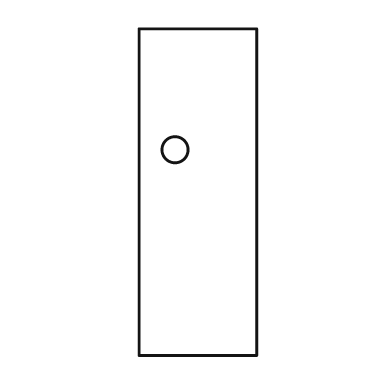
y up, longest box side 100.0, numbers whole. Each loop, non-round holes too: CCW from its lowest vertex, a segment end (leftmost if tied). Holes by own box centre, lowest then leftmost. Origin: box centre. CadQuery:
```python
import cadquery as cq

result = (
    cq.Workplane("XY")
    .moveTo(-18.0, -50.0)
    .lineTo(18.0, -50.0)
    .lineTo(18.0, 50.0)
    .lineTo(-18.0, 50.0)
    .close()
    .moveTo(-7.0, 13.0)
    .circle(4.0)
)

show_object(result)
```